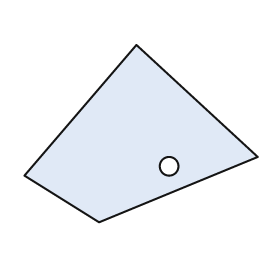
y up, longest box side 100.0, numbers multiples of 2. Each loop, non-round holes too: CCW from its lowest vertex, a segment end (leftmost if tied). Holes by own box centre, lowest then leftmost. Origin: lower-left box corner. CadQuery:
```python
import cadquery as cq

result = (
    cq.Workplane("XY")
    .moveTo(32.0, 0.0)
    .lineTo(100.0, 28.0)
    .lineTo(48.0, 76.0)
    .lineTo(0.0, 20.0)
    .close()
    .moveTo(62.0, 24.0)
    .circle(4.0)
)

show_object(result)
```